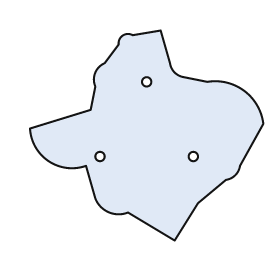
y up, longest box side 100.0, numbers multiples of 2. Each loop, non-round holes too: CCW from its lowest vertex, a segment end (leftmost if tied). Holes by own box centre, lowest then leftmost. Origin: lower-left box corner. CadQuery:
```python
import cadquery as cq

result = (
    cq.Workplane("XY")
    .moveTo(62.0, 0.0)
    .lineTo(72.0, 16.0)
    .lineTo(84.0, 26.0)
    .threePointArc((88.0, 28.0), (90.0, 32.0))
    .lineTo(100.0, 50.0)
    .threePointArc((92.0, 64.0), (76.0, 68.0))
    .lineTo(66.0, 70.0)
    .threePointArc((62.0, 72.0), (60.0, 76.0))
    .lineTo(56.0, 90.0)
    .lineTo(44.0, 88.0)
    .threePointArc((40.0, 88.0), (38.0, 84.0))
    .lineTo(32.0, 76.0)
    .threePointArc((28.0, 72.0), (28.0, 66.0))
    .lineTo(26.0, 56.0)
    .lineTo(0.0, 48.0)
    .threePointArc((8.0, 34.0), (24.0, 32.0))
    .lineTo(28.0, 18.0)
    .threePointArc((34.0, 12.0), (42.0, 12.0))
    .close()
    .moveTo(30.0, 36.0)
    .circle(2.0)
    .moveTo(70.0, 36.0)
    .circle(2.0)
    .moveTo(50.0, 68.0)
    .circle(2.0)
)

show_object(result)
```